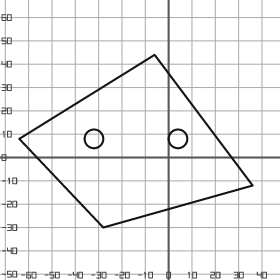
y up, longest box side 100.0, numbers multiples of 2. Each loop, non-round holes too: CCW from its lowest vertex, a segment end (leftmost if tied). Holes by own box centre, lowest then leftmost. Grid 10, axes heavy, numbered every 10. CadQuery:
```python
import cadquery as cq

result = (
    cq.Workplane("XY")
    .moveTo(-28.0, -30.0)
    .lineTo(36.0, -12.0)
    .lineTo(-6.0, 44.0)
    .lineTo(-64.0, 8.0)
    .close()
    .moveTo(-32.0, 8.0)
    .circle(4.0)
    .moveTo(4.0, 8.0)
    .circle(4.0)
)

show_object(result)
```